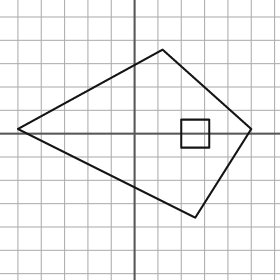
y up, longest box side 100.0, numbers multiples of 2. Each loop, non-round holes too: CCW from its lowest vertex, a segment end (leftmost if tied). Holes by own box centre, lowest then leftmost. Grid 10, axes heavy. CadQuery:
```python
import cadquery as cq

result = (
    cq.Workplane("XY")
    .moveTo(26.0, -36.0)
    .lineTo(50.0, 2.0)
    .lineTo(12.0, 36.0)
    .lineTo(-50.0, 2.0)
    .close()
    .moveTo(20.0, -6.0)
    .lineTo(32.0, -6.0)
    .lineTo(32.0, 6.0)
    .lineTo(20.0, 6.0)
    .close()
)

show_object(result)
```